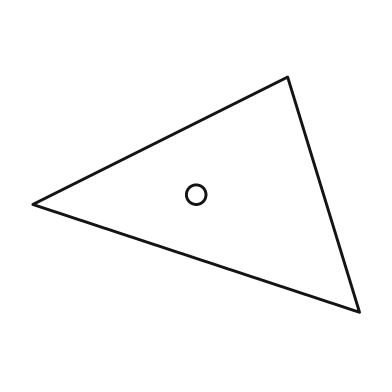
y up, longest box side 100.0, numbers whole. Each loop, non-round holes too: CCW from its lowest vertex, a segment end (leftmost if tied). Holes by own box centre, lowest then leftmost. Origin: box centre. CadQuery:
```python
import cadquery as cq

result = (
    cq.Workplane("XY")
    .moveTo(50.0, -36.0)
    .lineTo(28.0, 36.0)
    .lineTo(-50.0, -3.0)
    .close()
    .moveTo(0.0, 0.0)
    .circle(3.0)
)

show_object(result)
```